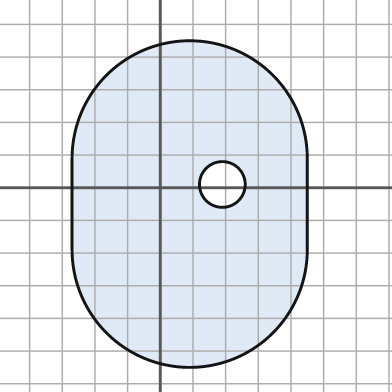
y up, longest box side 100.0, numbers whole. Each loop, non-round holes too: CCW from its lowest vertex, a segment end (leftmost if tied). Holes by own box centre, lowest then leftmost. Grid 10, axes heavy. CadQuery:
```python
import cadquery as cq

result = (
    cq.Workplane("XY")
    .moveTo(-27.0, -19.0)
    .threePointArc((9.0, -55.0), (45.0, -19.0))
    .lineTo(45.0, 9.0)
    .threePointArc((9.0, 45.0), (-27.0, 9.0))
    .close()
    .moveTo(19.0, 1.0)
    .circle(7.0)
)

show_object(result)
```